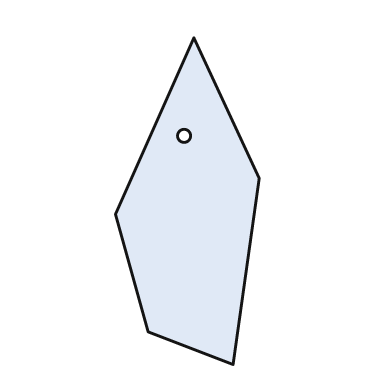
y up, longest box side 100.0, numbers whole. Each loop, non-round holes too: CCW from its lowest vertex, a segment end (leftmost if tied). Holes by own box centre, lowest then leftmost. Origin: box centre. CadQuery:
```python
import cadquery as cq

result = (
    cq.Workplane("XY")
    .moveTo(14.0, -50.0)
    .lineTo(22.0, 7.0)
    .lineTo(2.0, 50.0)
    .lineTo(-22.0, -4.0)
    .lineTo(-12.0, -40.0)
    .close()
    .moveTo(-1.0, 20.0)
    .circle(2.0)
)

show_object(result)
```